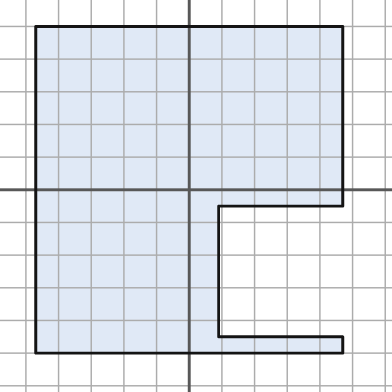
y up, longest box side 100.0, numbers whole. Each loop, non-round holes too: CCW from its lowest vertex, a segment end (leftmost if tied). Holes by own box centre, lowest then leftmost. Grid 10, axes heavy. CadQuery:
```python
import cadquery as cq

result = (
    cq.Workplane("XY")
    .moveTo(-47.0, -50.0)
    .lineTo(47.0, -50.0)
    .lineTo(47.0, -45.0)
    .lineTo(9.0, -45.0)
    .lineTo(9.0, -5.0)
    .lineTo(47.0, -5.0)
    .lineTo(47.0, 50.0)
    .lineTo(-47.0, 50.0)
    .close()
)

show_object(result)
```